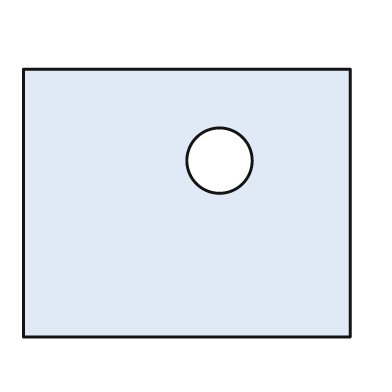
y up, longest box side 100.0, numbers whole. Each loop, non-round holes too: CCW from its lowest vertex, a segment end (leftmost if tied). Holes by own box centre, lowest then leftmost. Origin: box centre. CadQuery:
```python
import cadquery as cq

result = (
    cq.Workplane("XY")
    .moveTo(-50.0, -41.0)
    .lineTo(50.0, -41.0)
    .lineTo(50.0, 41.0)
    .lineTo(-50.0, 41.0)
    .close()
    .moveTo(10.0, 13.0)
    .circle(10.0)
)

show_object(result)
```